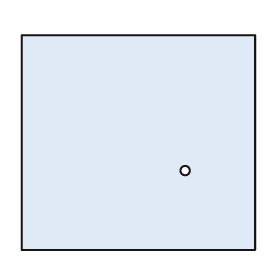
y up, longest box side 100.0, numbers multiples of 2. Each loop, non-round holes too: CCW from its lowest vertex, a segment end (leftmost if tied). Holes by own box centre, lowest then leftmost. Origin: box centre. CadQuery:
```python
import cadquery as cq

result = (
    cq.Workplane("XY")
    .moveTo(-50.0, -46.0)
    .lineTo(50.0, -46.0)
    .lineTo(50.0, 46.0)
    .lineTo(-50.0, 46.0)
    .close()
    .moveTo(20.0, -12.0)
    .circle(2.0)
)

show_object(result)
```